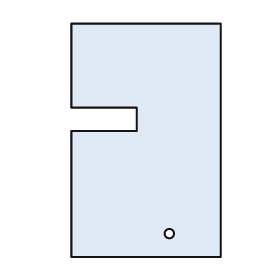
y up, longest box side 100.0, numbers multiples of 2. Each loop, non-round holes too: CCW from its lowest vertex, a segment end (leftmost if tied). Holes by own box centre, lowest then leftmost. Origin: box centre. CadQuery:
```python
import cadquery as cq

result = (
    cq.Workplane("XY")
    .moveTo(-32.0, -50.0)
    .lineTo(32.0, -50.0)
    .lineTo(32.0, 50.0)
    .lineTo(-32.0, 50.0)
    .lineTo(-32.0, 14.0)
    .lineTo(-4.0, 14.0)
    .lineTo(-4.0, 4.0)
    .lineTo(-32.0, 4.0)
    .close()
    .moveTo(10.0, -40.0)
    .circle(2.0)
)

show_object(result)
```